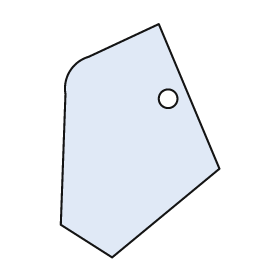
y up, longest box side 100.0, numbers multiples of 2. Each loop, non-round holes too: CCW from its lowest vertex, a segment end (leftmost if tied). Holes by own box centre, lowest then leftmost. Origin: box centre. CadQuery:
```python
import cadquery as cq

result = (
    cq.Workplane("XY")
    .moveTo(-12.0, -50.0)
    .lineTo(34.0, -12.0)
    .lineTo(8.0, 50.0)
    .lineTo(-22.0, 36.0)
    .threePointArc((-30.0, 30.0), (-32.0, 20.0))
    .lineTo(-34.0, -36.0)
    .close()
    .moveTo(12.0, 18.0)
    .circle(4.0)
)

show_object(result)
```